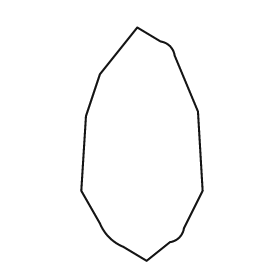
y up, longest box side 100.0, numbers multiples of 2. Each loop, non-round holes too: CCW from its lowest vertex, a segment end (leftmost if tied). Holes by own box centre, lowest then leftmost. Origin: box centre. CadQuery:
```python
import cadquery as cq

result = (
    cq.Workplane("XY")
    .moveTo(2.0, -50.0)
    .lineTo(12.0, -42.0)
    .threePointArc((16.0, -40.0), (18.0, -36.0))
    .lineTo(26.0, -20.0)
    .lineTo(24.0, 14.0)
    .lineTo(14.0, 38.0)
    .threePointArc((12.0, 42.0), (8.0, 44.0))
    .lineTo(-2.0, 50.0)
    .lineTo(-18.0, 30.0)
    .lineTo(-24.0, 12.0)
    .lineTo(-26.0, -20.0)
    .lineTo(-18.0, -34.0)
    .threePointArc((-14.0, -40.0), (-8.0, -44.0))
    .close()
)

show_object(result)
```